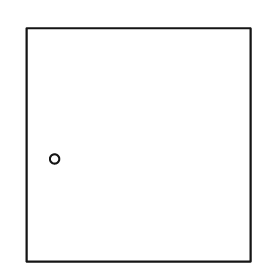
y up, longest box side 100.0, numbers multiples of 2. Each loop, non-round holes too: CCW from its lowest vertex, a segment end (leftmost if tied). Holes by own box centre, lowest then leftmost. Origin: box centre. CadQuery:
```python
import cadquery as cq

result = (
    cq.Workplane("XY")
    .moveTo(-48.0, -50.0)
    .lineTo(48.0, -50.0)
    .lineTo(48.0, 50.0)
    .lineTo(-48.0, 50.0)
    .close()
    .moveTo(-36.0, -6.0)
    .circle(2.0)
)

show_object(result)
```